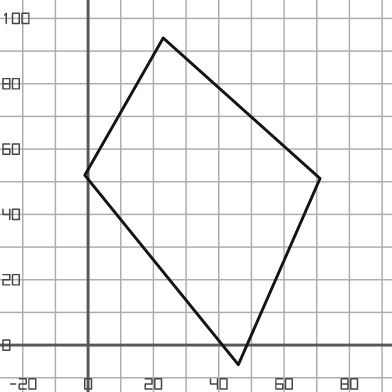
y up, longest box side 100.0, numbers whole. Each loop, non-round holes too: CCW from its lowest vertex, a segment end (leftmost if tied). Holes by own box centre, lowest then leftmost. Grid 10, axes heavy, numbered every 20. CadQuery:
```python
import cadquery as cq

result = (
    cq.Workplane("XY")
    .moveTo(46.0, -6.0)
    .lineTo(71.0, 51.0)
    .lineTo(23.0, 94.0)
    .lineTo(-1.0, 52.0)
    .close()
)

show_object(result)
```